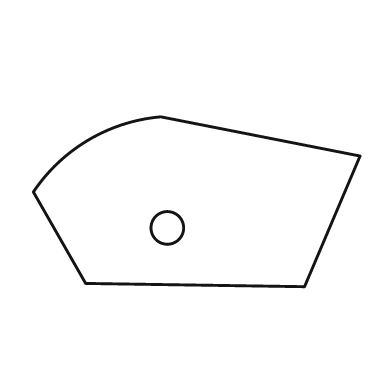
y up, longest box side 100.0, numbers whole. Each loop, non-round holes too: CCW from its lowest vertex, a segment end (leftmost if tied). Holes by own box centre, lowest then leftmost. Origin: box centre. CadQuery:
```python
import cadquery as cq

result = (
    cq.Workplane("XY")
    .moveTo(33.0, -26.0)
    .lineTo(50.0, 14.0)
    .lineTo(-11.0, 26.0)
    .threePointArc((-33.0, 19.0), (-50.0, 3.0))
    .lineTo(-34.0, -25.0)
    .close()
    .moveTo(-9.0, -8.0)
    .circle(5.0)
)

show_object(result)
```